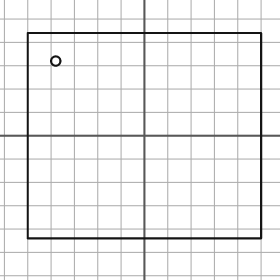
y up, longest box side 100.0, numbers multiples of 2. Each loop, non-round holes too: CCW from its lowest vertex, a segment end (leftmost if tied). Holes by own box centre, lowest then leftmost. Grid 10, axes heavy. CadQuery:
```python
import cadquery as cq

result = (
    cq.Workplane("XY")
    .moveTo(-50.0, -44.0)
    .lineTo(50.0, -44.0)
    .lineTo(50.0, 44.0)
    .lineTo(-50.0, 44.0)
    .close()
    .moveTo(-38.0, 32.0)
    .circle(2.0)
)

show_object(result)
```